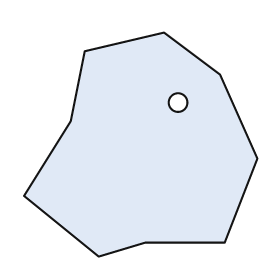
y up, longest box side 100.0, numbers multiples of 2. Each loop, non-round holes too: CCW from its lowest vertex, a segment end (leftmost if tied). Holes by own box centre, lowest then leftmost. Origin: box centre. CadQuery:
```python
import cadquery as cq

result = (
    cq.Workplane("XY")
    .moveTo(-18.0, -48.0)
    .lineTo(2.0, -42.0)
    .lineTo(36.0, -42.0)
    .lineTo(50.0, -6.0)
    .lineTo(34.0, 30.0)
    .lineTo(10.0, 48.0)
    .lineTo(-24.0, 40.0)
    .lineTo(-30.0, 10.0)
    .lineTo(-50.0, -22.0)
    .close()
    .moveTo(16.0, 18.0)
    .circle(4.0)
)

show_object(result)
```